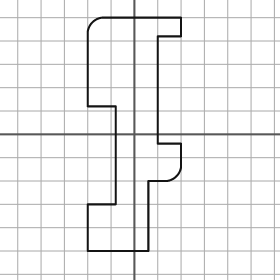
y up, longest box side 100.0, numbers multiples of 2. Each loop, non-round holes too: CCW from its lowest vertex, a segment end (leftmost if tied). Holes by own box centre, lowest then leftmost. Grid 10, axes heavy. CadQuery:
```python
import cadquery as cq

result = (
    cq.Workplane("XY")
    .moveTo(-20.0, -50.0)
    .lineTo(6.0, -50.0)
    .lineTo(6.0, -20.0)
    .lineTo(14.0, -20.0)
    .threePointArc((18.0, -18.0), (20.0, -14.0))
    .lineTo(20.0, -4.0)
    .lineTo(10.0, -4.0)
    .lineTo(10.0, 42.0)
    .lineTo(20.0, 42.0)
    .lineTo(20.0, 50.0)
    .lineTo(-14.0, 50.0)
    .threePointArc((-18.0, 48.0), (-20.0, 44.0))
    .lineTo(-20.0, 12.0)
    .lineTo(-8.0, 12.0)
    .lineTo(-8.0, -30.0)
    .lineTo(-20.0, -30.0)
    .close()
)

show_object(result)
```